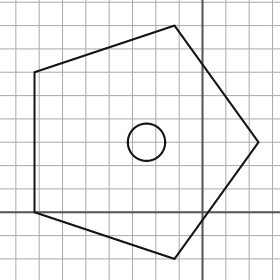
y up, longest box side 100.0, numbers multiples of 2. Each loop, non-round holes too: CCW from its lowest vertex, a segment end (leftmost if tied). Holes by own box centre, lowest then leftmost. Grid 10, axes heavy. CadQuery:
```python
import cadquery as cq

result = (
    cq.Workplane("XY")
    .moveTo(-12.0, -20.0)
    .lineTo(24.0, 30.0)
    .lineTo(-12.0, 80.0)
    .lineTo(-72.0, 60.0)
    .lineTo(-72.0, 0.0)
    .close()
    .moveTo(-24.0, 30.0)
    .circle(8.0)
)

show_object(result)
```